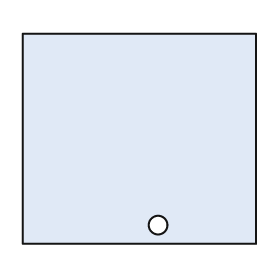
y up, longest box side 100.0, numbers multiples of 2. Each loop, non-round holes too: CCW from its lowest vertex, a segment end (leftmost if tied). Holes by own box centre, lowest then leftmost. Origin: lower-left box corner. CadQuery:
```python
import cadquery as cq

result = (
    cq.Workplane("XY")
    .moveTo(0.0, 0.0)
    .lineTo(100.0, 0.0)
    .lineTo(100.0, 90.0)
    .lineTo(0.0, 90.0)
    .close()
    .moveTo(58.0, 8.0)
    .circle(4.0)
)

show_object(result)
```